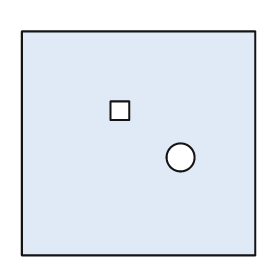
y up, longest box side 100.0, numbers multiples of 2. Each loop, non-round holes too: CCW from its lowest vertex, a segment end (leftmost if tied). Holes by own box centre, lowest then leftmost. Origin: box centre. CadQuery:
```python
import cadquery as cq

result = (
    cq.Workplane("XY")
    .moveTo(-50.0, -48.0)
    .lineTo(50.0, -48.0)
    .lineTo(50.0, 48.0)
    .lineTo(-50.0, 48.0)
    .close()
    .moveTo(18.0, -6.0)
    .circle(6.0)
    .moveTo(-12.0, 10.0)
    .lineTo(-4.0, 10.0)
    .lineTo(-4.0, 18.0)
    .lineTo(-12.0, 18.0)
    .close()
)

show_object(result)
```